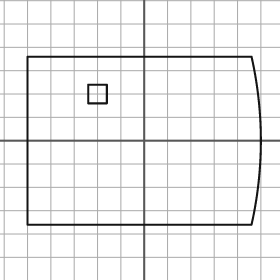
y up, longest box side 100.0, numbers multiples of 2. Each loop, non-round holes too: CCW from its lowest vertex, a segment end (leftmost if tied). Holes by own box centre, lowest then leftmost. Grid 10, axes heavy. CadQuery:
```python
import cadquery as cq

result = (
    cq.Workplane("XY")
    .moveTo(-50.0, -36.0)
    .lineTo(46.0, -36.0)
    .threePointArc((50.0, 0.0), (46.0, 36.0))
    .lineTo(-50.0, 36.0)
    .close()
    .moveTo(-24.0, 16.0)
    .lineTo(-16.0, 16.0)
    .lineTo(-16.0, 24.0)
    .lineTo(-24.0, 24.0)
    .close()
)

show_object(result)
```